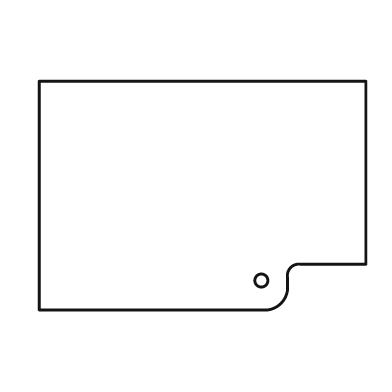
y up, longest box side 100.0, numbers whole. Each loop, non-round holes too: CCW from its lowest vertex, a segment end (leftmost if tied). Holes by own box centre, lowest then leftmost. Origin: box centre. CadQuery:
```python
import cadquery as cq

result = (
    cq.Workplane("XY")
    .moveTo(-50.0, -35.0)
    .lineTo(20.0, -35.0)
    .threePointArc((24.0, -33.0), (26.0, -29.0))
    .lineTo(26.0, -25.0)
    .threePointArc((27.0, -22.0), (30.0, -21.0))
    .lineTo(50.0, -21.0)
    .lineTo(50.0, 35.0)
    .lineTo(-50.0, 35.0)
    .close()
    .moveTo(18.0, -26.0)
    .circle(2.0)
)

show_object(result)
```